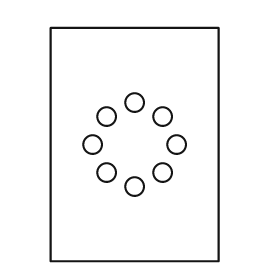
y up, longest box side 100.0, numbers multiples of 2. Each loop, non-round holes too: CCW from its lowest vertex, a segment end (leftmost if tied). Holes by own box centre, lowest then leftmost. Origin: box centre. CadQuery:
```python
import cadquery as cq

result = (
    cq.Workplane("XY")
    .moveTo(-36.0, -50.0)
    .lineTo(36.0, -50.0)
    .lineTo(36.0, 50.0)
    .lineTo(-36.0, 50.0)
    .close()
    .moveTo(0.0, -18.0)
    .circle(4.0)
    .moveTo(-12.0, -12.0)
    .circle(4.0)
    .moveTo(12.0, -12.0)
    .circle(4.0)
    .moveTo(-18.0, 0.0)
    .circle(4.0)
    .moveTo(18.0, 0.0)
    .circle(4.0)
    .moveTo(-12.0, 12.0)
    .circle(4.0)
    .moveTo(12.0, 12.0)
    .circle(4.0)
    .moveTo(0.0, 18.0)
    .circle(4.0)
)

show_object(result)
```